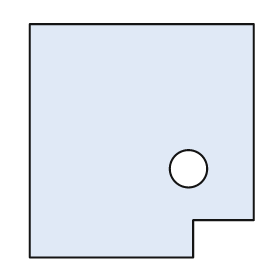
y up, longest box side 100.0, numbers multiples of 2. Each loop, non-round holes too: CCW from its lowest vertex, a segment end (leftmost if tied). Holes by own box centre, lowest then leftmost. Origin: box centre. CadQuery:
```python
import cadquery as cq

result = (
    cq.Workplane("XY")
    .moveTo(-48.0, -50.0)
    .lineTo(22.0, -50.0)
    .lineTo(22.0, -34.0)
    .lineTo(48.0, -34.0)
    .lineTo(48.0, 50.0)
    .lineTo(-48.0, 50.0)
    .close()
    .moveTo(20.0, -12.0)
    .circle(8.0)
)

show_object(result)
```